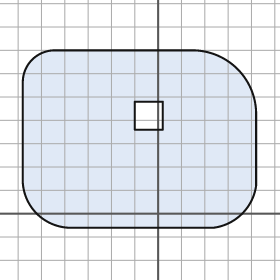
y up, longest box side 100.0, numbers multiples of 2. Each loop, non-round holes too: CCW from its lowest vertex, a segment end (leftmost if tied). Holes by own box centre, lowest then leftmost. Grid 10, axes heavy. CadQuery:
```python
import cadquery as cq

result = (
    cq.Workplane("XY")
    .moveTo(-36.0, -6.0)
    .lineTo(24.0, -6.0)
    .threePointArc((36.0, 0.0), (42.0, 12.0))
    .lineTo(42.0, 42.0)
    .threePointArc((34.0, 62.0), (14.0, 70.0))
    .lineTo(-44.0, 70.0)
    .threePointArc((-54.0, 66.0), (-58.0, 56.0))
    .lineTo(-58.0, 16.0)
    .threePointArc((-52.0, 0.0), (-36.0, -6.0))
    .close()
    .moveTo(-10.0, 36.0)
    .lineTo(2.0, 36.0)
    .lineTo(2.0, 48.0)
    .lineTo(-10.0, 48.0)
    .close()
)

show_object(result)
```